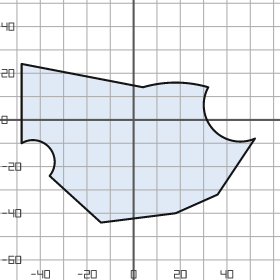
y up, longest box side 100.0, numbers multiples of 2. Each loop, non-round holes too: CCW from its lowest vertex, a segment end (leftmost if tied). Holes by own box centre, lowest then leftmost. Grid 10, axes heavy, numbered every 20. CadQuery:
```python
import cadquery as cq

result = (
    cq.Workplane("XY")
    .moveTo(-14.0, -44.0)
    .lineTo(18.0, -40.0)
    .lineTo(36.0, -32.0)
    .lineTo(52.0, -8.0)
    .threePointArc((34.0, -4.0), (32.0, 14.0))
    .threePointArc((18.0, 16.0), (4.0, 14.0))
    .lineTo(-48.0, 24.0)
    .lineTo(-48.0, -10.0)
    .threePointArc((-36.0, -12.0), (-36.0, -24.0))
    .close()
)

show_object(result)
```